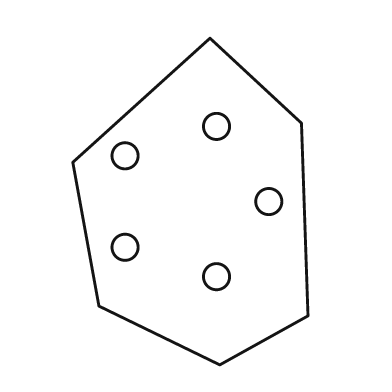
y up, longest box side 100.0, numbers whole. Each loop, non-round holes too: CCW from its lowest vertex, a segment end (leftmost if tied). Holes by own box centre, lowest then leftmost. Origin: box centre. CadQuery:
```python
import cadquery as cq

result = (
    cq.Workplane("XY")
    .moveTo(9.0, -50.0)
    .lineTo(36.0, -35.0)
    .lineTo(34.0, 24.0)
    .lineTo(6.0, 50.0)
    .lineTo(-36.0, 12.0)
    .lineTo(-28.0, -32.0)
    .close()
    .moveTo(8.0, -23.0)
    .circle(4.0)
    .moveTo(-20.0, -14.0)
    .circle(4.0)
    .moveTo(24.0, 0.0)
    .circle(4.0)
    .moveTo(-20.0, 14.0)
    .circle(4.0)
    .moveTo(8.0, 23.0)
    .circle(4.0)
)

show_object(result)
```